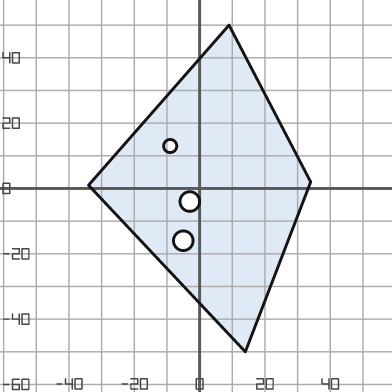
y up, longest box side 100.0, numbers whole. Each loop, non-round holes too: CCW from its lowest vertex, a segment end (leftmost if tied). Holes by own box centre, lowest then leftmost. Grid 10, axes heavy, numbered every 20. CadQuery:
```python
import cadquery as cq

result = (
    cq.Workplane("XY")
    .moveTo(14.0, -50.0)
    .lineTo(34.0, 2.0)
    .lineTo(9.0, 50.0)
    .lineTo(-34.0, 1.0)
    .close()
    .moveTo(-5.0, -16.0)
    .circle(3.0)
    .moveTo(-3.0, -4.0)
    .circle(3.0)
    .moveTo(-9.0, 13.0)
    .circle(2.0)
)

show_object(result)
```